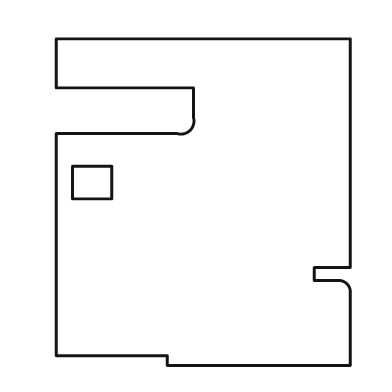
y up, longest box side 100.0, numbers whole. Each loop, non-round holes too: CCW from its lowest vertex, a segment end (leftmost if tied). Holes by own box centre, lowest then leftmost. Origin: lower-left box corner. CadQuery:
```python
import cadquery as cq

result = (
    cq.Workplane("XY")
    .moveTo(34.0, 0.0)
    .lineTo(90.0, 0.0)
    .lineTo(90.0, 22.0)
    .threePointArc((89.0, 25.0), (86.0, 26.0))
    .lineTo(79.0, 26.0)
    .lineTo(79.0, 30.0)
    .lineTo(90.0, 30.0)
    .lineTo(90.0, 100.0)
    .lineTo(0.0, 100.0)
    .lineTo(0.0, 85.0)
    .lineTo(42.0, 85.0)
    .lineTo(42.0, 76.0)
    .threePointArc((41.0, 72.0), (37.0, 71.0))
    .lineTo(0.0, 71.0)
    .lineTo(0.0, 3.0)
    .lineTo(34.0, 3.0)
    .close()
    .moveTo(5.0, 51.0)
    .lineTo(17.0, 51.0)
    .lineTo(17.0, 61.0)
    .lineTo(5.0, 61.0)
    .close()
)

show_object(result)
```